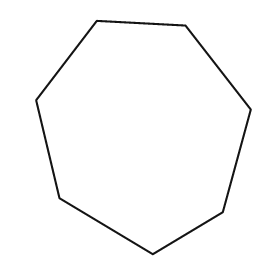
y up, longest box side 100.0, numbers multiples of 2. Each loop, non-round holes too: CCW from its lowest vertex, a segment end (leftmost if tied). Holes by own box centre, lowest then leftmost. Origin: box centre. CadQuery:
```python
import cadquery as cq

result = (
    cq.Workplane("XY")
    .moveTo(4.0, -50.0)
    .lineTo(34.0, -32.0)
    .lineTo(46.0, 12.0)
    .lineTo(18.0, 48.0)
    .lineTo(-20.0, 50.0)
    .lineTo(-46.0, 16.0)
    .lineTo(-36.0, -26.0)
    .close()
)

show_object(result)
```